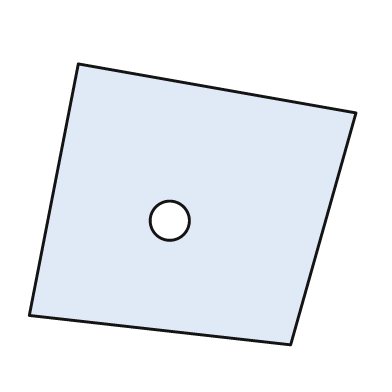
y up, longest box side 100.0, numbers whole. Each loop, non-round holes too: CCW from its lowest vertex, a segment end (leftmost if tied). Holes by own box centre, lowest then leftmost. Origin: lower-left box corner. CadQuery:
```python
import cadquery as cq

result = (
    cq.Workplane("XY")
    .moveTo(80.0, 0.0)
    .lineTo(100.0, 71.0)
    .lineTo(15.0, 86.0)
    .lineTo(0.0, 9.0)
    .close()
    .moveTo(43.0, 38.0)
    .circle(6.0)
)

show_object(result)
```